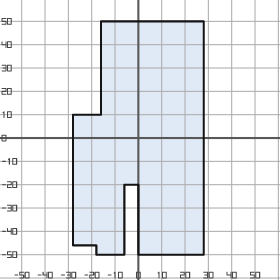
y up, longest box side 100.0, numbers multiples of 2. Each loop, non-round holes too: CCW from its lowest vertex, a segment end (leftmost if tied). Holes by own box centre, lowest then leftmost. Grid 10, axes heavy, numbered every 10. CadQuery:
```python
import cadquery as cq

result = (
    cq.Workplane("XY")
    .moveTo(-18.0, -50.0)
    .lineTo(-6.0, -50.0)
    .lineTo(-6.0, -20.0)
    .lineTo(0.0, -20.0)
    .lineTo(0.0, -50.0)
    .lineTo(28.0, -50.0)
    .lineTo(28.0, 50.0)
    .lineTo(-16.0, 50.0)
    .lineTo(-16.0, 10.0)
    .lineTo(-28.0, 10.0)
    .lineTo(-28.0, -46.0)
    .lineTo(-18.0, -46.0)
    .close()
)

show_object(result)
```